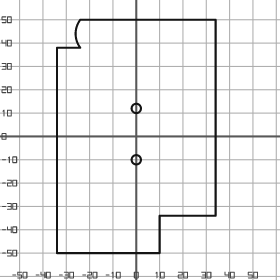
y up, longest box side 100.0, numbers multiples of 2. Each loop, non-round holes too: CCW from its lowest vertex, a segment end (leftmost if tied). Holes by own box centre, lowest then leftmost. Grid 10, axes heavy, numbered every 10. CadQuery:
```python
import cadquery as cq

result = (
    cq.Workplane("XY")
    .moveTo(-34.0, -50.0)
    .lineTo(10.0, -50.0)
    .lineTo(10.0, -34.0)
    .lineTo(34.0, -34.0)
    .lineTo(34.0, 50.0)
    .lineTo(-24.0, 50.0)
    .threePointArc((-26.0, 44.0), (-24.0, 38.0))
    .lineTo(-34.0, 38.0)
    .close()
    .moveTo(0.0, -10.0)
    .circle(2.0)
    .moveTo(0.0, 12.0)
    .circle(2.0)
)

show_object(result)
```